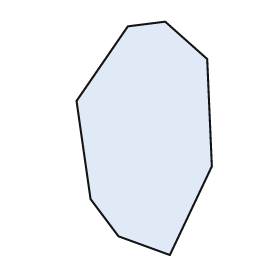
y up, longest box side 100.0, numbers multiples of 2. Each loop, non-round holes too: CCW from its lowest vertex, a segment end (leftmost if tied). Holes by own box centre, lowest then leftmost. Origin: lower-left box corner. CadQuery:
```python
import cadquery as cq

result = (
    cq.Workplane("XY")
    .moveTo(40.0, 0.0)
    .lineTo(58.0, 38.0)
    .lineTo(56.0, 84.0)
    .lineTo(38.0, 100.0)
    .lineTo(22.0, 98.0)
    .lineTo(0.0, 66.0)
    .lineTo(6.0, 24.0)
    .lineTo(18.0, 8.0)
    .close()
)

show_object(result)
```